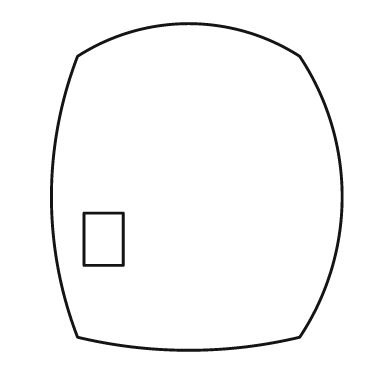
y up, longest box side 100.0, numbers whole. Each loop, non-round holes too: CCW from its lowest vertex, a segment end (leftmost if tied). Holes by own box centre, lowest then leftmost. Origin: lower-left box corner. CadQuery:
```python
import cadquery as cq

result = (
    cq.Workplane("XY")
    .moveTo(8.0, 4.0)
    .threePointArc((42.0, 0.0), (76.0, 4.0))
    .threePointArc((89.0, 47.0), (76.0, 90.0))
    .threePointArc((42.0, 100.0), (8.0, 90.0))
    .threePointArc((0.0, 47.0), (8.0, 4.0))
    .close()
    .moveTo(10.0, 26.0)
    .lineTo(22.0, 26.0)
    .lineTo(22.0, 42.0)
    .lineTo(10.0, 42.0)
    .close()
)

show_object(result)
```